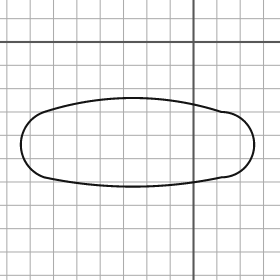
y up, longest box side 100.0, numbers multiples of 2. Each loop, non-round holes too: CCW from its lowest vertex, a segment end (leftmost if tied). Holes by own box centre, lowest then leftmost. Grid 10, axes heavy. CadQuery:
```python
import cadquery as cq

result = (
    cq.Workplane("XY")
    .moveTo(-64.0, -58.0)
    .threePointArc((-26.0, -62.0), (12.0, -58.0))
    .threePointArc((26.0, -44.0), (12.0, -30.0))
    .threePointArc((-26.0, -24.0), (-64.0, -30.0))
    .threePointArc((-74.0, -44.0), (-64.0, -58.0))
    .close()
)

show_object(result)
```